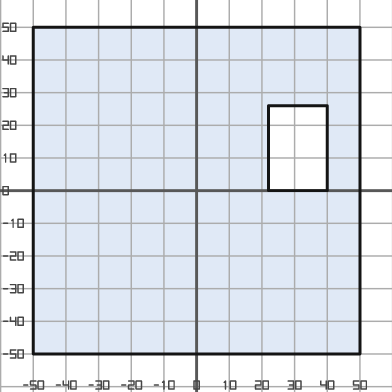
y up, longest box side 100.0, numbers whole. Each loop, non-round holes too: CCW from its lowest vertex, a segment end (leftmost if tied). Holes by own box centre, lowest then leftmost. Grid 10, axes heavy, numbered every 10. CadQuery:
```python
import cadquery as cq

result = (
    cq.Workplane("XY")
    .moveTo(-50.0, -50.0)
    .lineTo(50.0, -50.0)
    .lineTo(50.0, 50.0)
    .lineTo(-50.0, 50.0)
    .close()
    .moveTo(22.0, 0.0)
    .lineTo(40.0, 0.0)
    .lineTo(40.0, 26.0)
    .lineTo(22.0, 26.0)
    .close()
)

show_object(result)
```